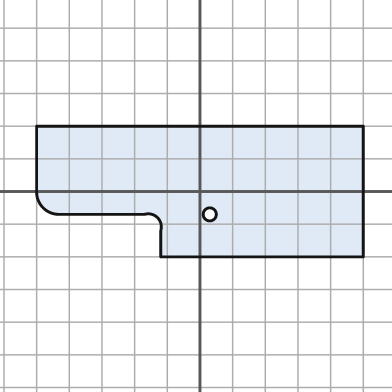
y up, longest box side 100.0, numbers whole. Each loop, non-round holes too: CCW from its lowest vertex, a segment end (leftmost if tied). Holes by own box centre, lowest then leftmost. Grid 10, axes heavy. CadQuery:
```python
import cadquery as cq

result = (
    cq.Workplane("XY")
    .moveTo(-12.0, -20.0)
    .lineTo(50.0, -20.0)
    .lineTo(50.0, 20.0)
    .lineTo(-50.0, 20.0)
    .lineTo(-50.0, 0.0)
    .threePointArc((-48.0, -5.0), (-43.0, -7.0))
    .lineTo(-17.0, -7.0)
    .threePointArc((-13.0, -8.0), (-12.0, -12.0))
    .close()
    .moveTo(3.0, -7.0)
    .circle(2.0)
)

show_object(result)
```